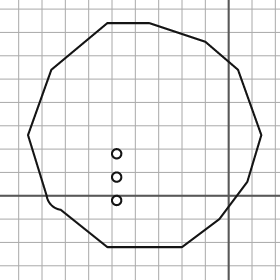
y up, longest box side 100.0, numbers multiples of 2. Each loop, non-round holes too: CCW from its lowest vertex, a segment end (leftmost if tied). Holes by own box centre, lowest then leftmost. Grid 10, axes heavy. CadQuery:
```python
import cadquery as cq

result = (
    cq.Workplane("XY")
    .moveTo(-52.0, -22.0)
    .lineTo(-20.0, -22.0)
    .lineTo(-4.0, -10.0)
    .lineTo(8.0, 6.0)
    .lineTo(14.0, 26.0)
    .lineTo(4.0, 54.0)
    .lineTo(-10.0, 66.0)
    .lineTo(-34.0, 74.0)
    .lineTo(-52.0, 74.0)
    .lineTo(-76.0, 54.0)
    .lineTo(-86.0, 26.0)
    .lineTo(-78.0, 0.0)
    .threePointArc((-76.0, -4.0), (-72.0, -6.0))
    .close()
    .moveTo(-48.0, -2.0)
    .circle(2.0)
    .moveTo(-48.0, 8.0)
    .circle(2.0)
    .moveTo(-48.0, 18.0)
    .circle(2.0)
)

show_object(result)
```